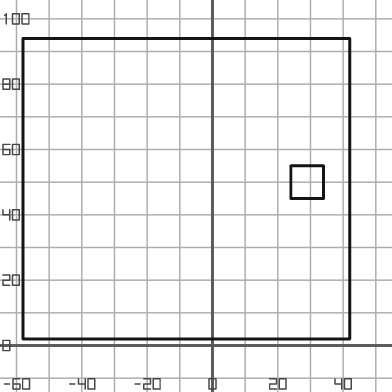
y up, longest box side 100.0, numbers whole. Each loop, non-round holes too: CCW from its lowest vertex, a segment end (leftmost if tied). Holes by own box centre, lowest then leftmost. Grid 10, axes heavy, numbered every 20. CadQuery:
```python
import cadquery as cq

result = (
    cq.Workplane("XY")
    .moveTo(-58.0, 2.0)
    .lineTo(42.0, 2.0)
    .lineTo(42.0, 94.0)
    .lineTo(-58.0, 94.0)
    .close()
    .moveTo(24.0, 45.0)
    .lineTo(34.0, 45.0)
    .lineTo(34.0, 55.0)
    .lineTo(24.0, 55.0)
    .close()
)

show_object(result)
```